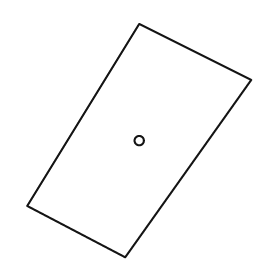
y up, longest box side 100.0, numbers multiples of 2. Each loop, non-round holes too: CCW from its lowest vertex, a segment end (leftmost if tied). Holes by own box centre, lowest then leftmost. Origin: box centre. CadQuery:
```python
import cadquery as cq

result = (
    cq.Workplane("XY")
    .moveTo(-6.0, -50.0)
    .lineTo(48.0, 26.0)
    .lineTo(0.0, 50.0)
    .lineTo(-48.0, -28.0)
    .close()
    .moveTo(0.0, 0.0)
    .circle(2.0)
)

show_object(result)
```